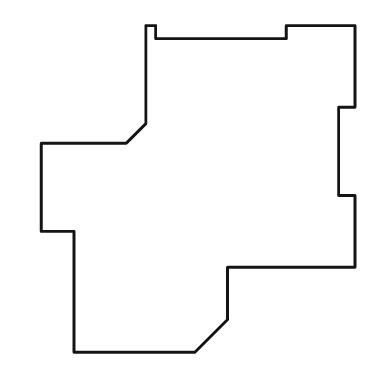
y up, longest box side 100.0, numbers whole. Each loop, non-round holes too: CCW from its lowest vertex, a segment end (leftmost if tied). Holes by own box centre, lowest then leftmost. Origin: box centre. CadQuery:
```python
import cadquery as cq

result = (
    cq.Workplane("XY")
    .moveTo(-38.0, -50.0)
    .lineTo(-1.0, -50.0)
    .lineTo(9.0, -40.0)
    .lineTo(9.0, -24.0)
    .lineTo(48.0, -24.0)
    .lineTo(48.0, -2.0)
    .lineTo(43.0, -2.0)
    .lineTo(43.0, 25.0)
    .lineTo(48.0, 25.0)
    .lineTo(48.0, 50.0)
    .lineTo(27.0, 50.0)
    .lineTo(27.0, 46.0)
    .lineTo(-13.0, 46.0)
    .lineTo(-13.0, 50.0)
    .lineTo(-16.0, 50.0)
    .lineTo(-16.0, 20.0)
    .lineTo(-22.0, 14.0)
    .lineTo(-48.0, 14.0)
    .lineTo(-48.0, -13.0)
    .lineTo(-38.0, -13.0)
    .close()
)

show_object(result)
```